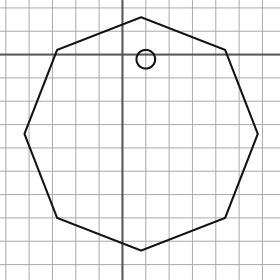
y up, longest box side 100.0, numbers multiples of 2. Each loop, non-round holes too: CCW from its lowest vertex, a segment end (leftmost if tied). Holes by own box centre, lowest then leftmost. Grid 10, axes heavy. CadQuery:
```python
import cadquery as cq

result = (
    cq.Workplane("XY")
    .moveTo(8.0, -84.0)
    .lineTo(44.0, -70.0)
    .lineTo(58.0, -34.0)
    .lineTo(44.0, 2.0)
    .lineTo(8.0, 16.0)
    .lineTo(-28.0, 2.0)
    .lineTo(-42.0, -34.0)
    .lineTo(-28.0, -70.0)
    .close()
    .moveTo(10.0, -2.0)
    .circle(4.0)
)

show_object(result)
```